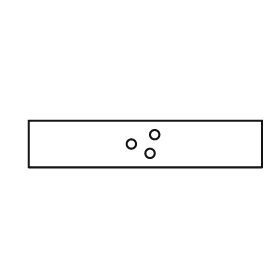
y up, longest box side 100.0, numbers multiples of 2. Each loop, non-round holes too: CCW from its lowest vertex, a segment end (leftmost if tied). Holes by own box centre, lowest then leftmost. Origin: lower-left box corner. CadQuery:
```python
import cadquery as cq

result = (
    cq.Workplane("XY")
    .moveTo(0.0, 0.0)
    .lineTo(100.0, 0.0)
    .lineTo(100.0, 20.0)
    .lineTo(0.0, 20.0)
    .close()
    .moveTo(52.0, 6.0)
    .circle(2.0)
    .moveTo(44.0, 10.0)
    .circle(2.0)
    .moveTo(54.0, 14.0)
    .circle(2.0)
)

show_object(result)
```